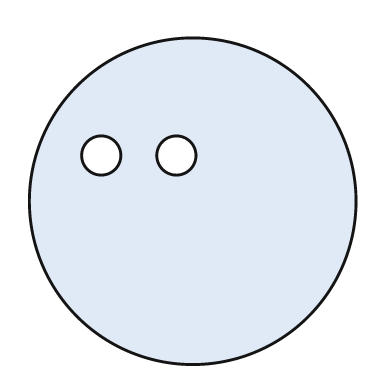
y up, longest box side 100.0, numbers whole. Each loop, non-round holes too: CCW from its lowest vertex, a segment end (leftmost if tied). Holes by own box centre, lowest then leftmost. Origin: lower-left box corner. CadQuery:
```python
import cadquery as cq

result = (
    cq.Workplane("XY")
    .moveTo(50.0, 50.0)
    .circle(50.0)
    .moveTo(22.0, 64.0)
    .circle(6.0)
    .moveTo(45.0, 64.0)
    .circle(6.0)
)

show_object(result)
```